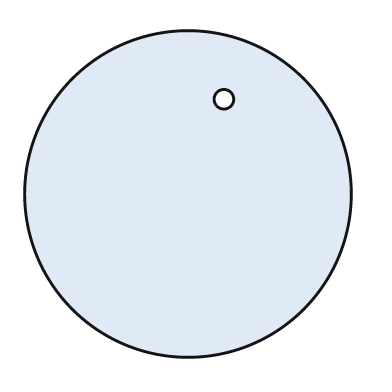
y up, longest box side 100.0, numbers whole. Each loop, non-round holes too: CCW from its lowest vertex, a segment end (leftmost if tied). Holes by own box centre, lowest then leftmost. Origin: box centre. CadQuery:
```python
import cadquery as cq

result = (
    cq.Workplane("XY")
    .moveTo(0.0, 0.0)
    .circle(50.0)
    .moveTo(11.0, 29.0)
    .circle(3.0)
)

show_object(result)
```